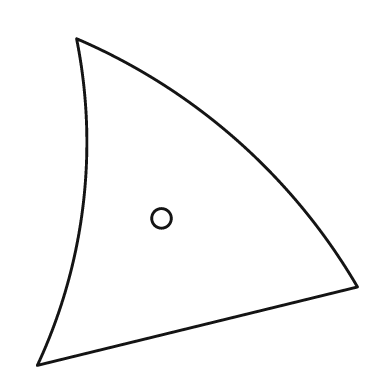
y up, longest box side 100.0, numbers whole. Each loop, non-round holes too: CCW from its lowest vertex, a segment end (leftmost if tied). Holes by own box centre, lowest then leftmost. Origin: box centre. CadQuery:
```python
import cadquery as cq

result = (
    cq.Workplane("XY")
    .moveTo(-49.0, -50.0)
    .lineTo(49.0, -26.0)
    .threePointArc((12.0, 19.0), (-37.0, 50.0))
    .threePointArc((-35.0, -1.0), (-49.0, -50.0))
    .close()
    .moveTo(-11.0, -5.0)
    .circle(3.0)
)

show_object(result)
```